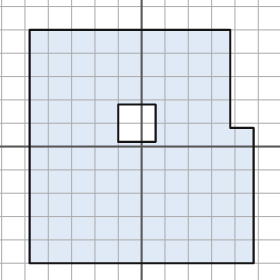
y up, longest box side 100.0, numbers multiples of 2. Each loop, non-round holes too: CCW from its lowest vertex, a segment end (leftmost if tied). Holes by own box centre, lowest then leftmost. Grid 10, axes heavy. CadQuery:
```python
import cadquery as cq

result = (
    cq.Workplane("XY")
    .moveTo(-48.0, -50.0)
    .lineTo(48.0, -50.0)
    .lineTo(48.0, 8.0)
    .lineTo(38.0, 8.0)
    .lineTo(38.0, 50.0)
    .lineTo(-48.0, 50.0)
    .close()
    .moveTo(-10.0, 2.0)
    .lineTo(6.0, 2.0)
    .lineTo(6.0, 18.0)
    .lineTo(-10.0, 18.0)
    .close()
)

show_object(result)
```